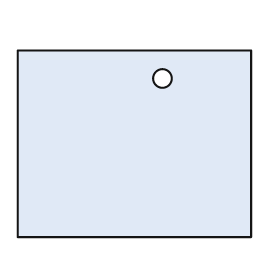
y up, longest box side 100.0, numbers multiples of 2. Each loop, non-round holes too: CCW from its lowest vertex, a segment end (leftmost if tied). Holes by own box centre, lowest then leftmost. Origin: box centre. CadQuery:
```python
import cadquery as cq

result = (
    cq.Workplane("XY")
    .moveTo(-50.0, -40.0)
    .lineTo(50.0, -40.0)
    .lineTo(50.0, 40.0)
    .lineTo(-50.0, 40.0)
    .close()
    .moveTo(12.0, 28.0)
    .circle(4.0)
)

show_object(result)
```